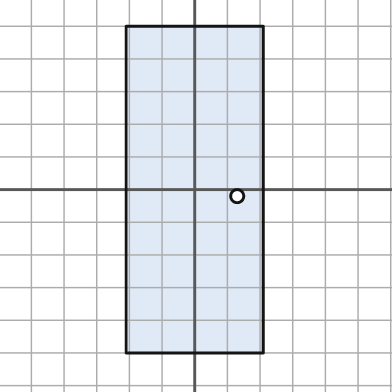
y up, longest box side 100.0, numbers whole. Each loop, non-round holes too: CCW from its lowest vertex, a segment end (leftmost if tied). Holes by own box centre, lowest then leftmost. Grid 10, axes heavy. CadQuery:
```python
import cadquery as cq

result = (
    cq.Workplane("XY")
    .moveTo(-21.0, -50.0)
    .lineTo(21.0, -50.0)
    .lineTo(21.0, 50.0)
    .lineTo(-21.0, 50.0)
    .close()
    .moveTo(13.0, -2.0)
    .circle(2.0)
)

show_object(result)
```